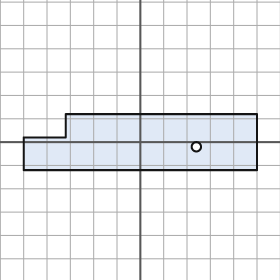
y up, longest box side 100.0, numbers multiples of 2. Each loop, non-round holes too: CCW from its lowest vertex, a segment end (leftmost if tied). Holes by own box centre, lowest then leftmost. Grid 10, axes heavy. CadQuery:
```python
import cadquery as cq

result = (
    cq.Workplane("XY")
    .moveTo(-50.0, -12.0)
    .lineTo(50.0, -12.0)
    .lineTo(50.0, 12.0)
    .lineTo(-32.0, 12.0)
    .lineTo(-32.0, 2.0)
    .lineTo(-50.0, 2.0)
    .close()
    .moveTo(24.0, -2.0)
    .circle(2.0)
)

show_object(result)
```